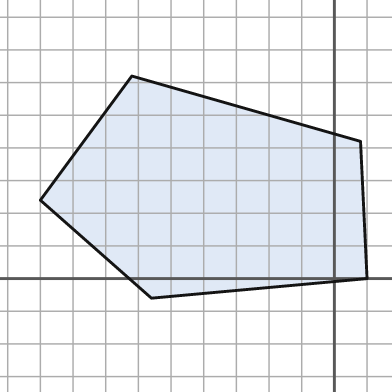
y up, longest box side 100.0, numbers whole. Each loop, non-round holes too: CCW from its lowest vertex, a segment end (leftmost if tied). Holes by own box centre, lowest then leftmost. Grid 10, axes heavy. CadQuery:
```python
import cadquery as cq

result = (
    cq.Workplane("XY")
    .moveTo(-56.0, -6.0)
    .lineTo(10.0, 0.0)
    .lineTo(8.0, 42.0)
    .lineTo(-62.0, 62.0)
    .lineTo(-90.0, 24.0)
    .close()
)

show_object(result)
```